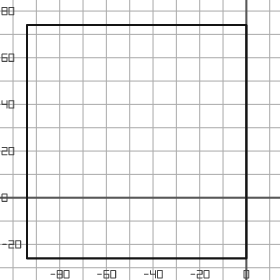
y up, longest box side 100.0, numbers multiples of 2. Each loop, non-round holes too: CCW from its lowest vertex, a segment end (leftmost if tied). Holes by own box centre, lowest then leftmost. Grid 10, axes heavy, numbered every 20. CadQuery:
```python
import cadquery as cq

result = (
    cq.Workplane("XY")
    .moveTo(-94.0, -26.0)
    .lineTo(0.0, -26.0)
    .lineTo(0.0, 74.0)
    .lineTo(-94.0, 74.0)
    .close()
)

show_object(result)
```